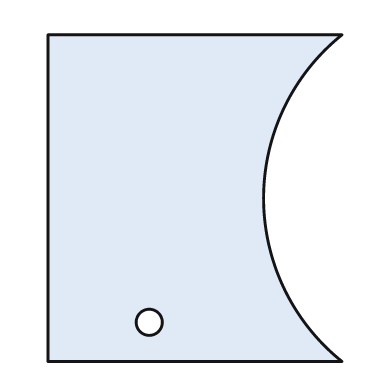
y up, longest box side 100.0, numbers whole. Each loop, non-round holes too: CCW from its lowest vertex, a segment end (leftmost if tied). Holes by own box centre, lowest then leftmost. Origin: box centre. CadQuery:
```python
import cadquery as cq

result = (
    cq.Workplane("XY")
    .moveTo(-45.0, -50.0)
    .lineTo(45.0, -50.0)
    .threePointArc((21.0, 0.0), (45.0, 50.0))
    .lineTo(-45.0, 50.0)
    .close()
    .moveTo(-14.0, -38.0)
    .circle(4.0)
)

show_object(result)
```